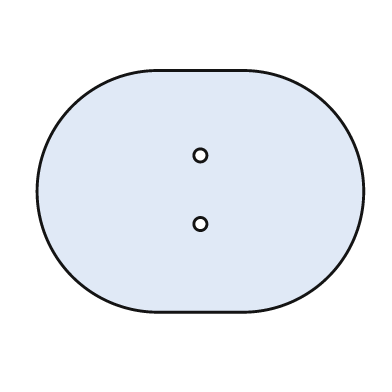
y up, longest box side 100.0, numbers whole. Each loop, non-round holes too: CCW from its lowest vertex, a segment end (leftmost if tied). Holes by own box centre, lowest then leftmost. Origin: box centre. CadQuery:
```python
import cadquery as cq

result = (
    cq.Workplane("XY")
    .moveTo(-13.0, -37.0)
    .lineTo(13.0, -37.0)
    .threePointArc((50.0, 0.0), (13.0, 37.0))
    .lineTo(-13.0, 37.0)
    .threePointArc((-50.0, 0.0), (-13.0, -37.0))
    .close()
    .moveTo(0.0, -10.0)
    .circle(2.0)
    .moveTo(0.0, 11.0)
    .circle(2.0)
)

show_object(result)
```